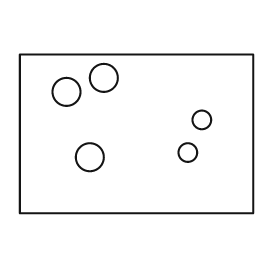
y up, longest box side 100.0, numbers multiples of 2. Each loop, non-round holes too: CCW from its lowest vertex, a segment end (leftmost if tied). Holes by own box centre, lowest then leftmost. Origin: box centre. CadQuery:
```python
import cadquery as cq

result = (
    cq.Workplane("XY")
    .moveTo(-50.0, -34.0)
    .lineTo(50.0, -34.0)
    .lineTo(50.0, 34.0)
    .lineTo(-50.0, 34.0)
    .close()
    .moveTo(-20.0, -10.0)
    .circle(6.0)
    .moveTo(22.0, -8.0)
    .circle(4.0)
    .moveTo(28.0, 6.0)
    .circle(4.0)
    .moveTo(-30.0, 18.0)
    .circle(6.0)
    .moveTo(-14.0, 24.0)
    .circle(6.0)
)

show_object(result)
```